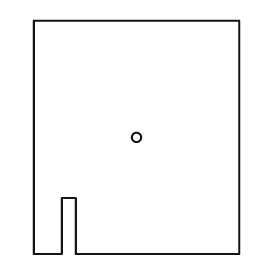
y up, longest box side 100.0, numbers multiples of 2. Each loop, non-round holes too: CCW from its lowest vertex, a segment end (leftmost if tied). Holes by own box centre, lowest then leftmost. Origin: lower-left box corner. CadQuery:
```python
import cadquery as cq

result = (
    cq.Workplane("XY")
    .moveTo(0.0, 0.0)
    .lineTo(12.0, 0.0)
    .lineTo(12.0, 24.0)
    .lineTo(18.0, 24.0)
    .lineTo(18.0, 0.0)
    .lineTo(88.0, 0.0)
    .lineTo(88.0, 100.0)
    .lineTo(0.0, 100.0)
    .close()
    .moveTo(44.0, 50.0)
    .circle(2.0)
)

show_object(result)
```